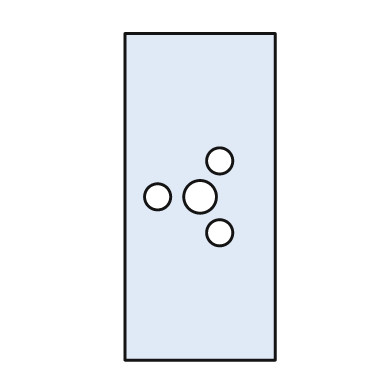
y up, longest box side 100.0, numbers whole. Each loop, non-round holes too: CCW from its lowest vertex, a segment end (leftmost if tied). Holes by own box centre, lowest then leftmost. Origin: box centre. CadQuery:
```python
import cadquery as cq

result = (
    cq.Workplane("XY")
    .moveTo(-23.0, -50.0)
    .lineTo(23.0, -50.0)
    .lineTo(23.0, 50.0)
    .lineTo(-23.0, 50.0)
    .close()
    .moveTo(6.0, -11.0)
    .circle(4.0)
    .moveTo(-13.0, 0.0)
    .circle(4.0)
    .moveTo(0.0, 0.0)
    .circle(5.0)
    .moveTo(6.0, 11.0)
    .circle(4.0)
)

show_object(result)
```